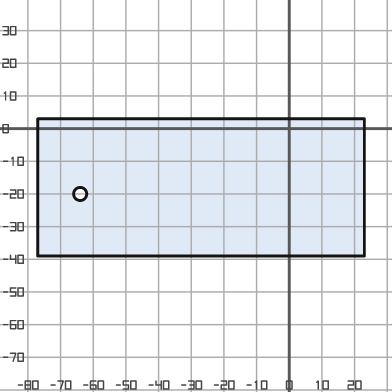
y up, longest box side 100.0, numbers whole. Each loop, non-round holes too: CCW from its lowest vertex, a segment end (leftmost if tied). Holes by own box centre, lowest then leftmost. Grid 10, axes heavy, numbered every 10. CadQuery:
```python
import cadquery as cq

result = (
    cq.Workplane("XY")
    .moveTo(-77.0, -39.0)
    .lineTo(23.0, -39.0)
    .lineTo(23.0, 3.0)
    .lineTo(-77.0, 3.0)
    .close()
    .moveTo(-64.0, -20.0)
    .circle(2.0)
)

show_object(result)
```